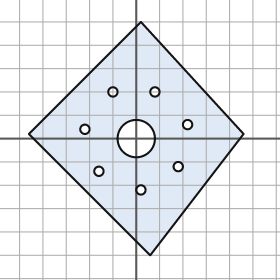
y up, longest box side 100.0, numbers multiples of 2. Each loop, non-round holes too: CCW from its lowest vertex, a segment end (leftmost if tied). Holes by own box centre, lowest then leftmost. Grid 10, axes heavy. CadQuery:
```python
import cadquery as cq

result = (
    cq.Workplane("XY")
    .moveTo(6.0, -50.0)
    .lineTo(46.0, 2.0)
    .lineTo(2.0, 50.0)
    .lineTo(-46.0, 2.0)
    .close()
    .moveTo(2.0, -22.0)
    .circle(2.0)
    .moveTo(-16.0, -14.0)
    .circle(2.0)
    .moveTo(18.0, -12.0)
    .circle(2.0)
    .moveTo(0.0, 0.0)
    .circle(8.0)
    .moveTo(-22.0, 4.0)
    .circle(2.0)
    .moveTo(22.0, 6.0)
    .circle(2.0)
    .moveTo(-10.0, 20.0)
    .circle(2.0)
    .moveTo(8.0, 20.0)
    .circle(2.0)
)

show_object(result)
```